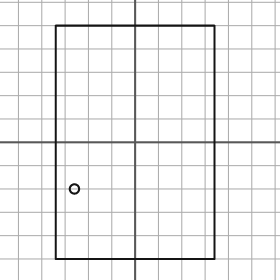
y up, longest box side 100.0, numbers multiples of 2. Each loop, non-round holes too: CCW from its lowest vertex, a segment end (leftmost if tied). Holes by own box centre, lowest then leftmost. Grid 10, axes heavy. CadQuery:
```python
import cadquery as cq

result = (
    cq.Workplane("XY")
    .moveTo(-34.0, -50.0)
    .lineTo(34.0, -50.0)
    .lineTo(34.0, 50.0)
    .lineTo(-34.0, 50.0)
    .close()
    .moveTo(-26.0, -20.0)
    .circle(2.0)
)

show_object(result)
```